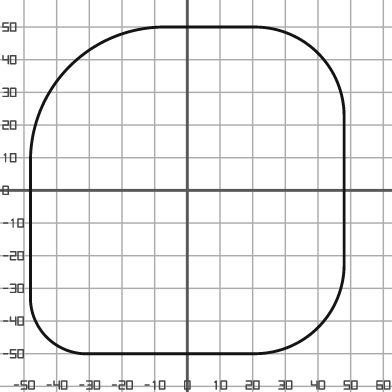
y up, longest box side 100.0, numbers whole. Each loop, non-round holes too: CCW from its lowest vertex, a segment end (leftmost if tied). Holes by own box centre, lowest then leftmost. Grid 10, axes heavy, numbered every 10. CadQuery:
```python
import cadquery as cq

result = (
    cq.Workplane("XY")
    .moveTo(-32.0, -50.0)
    .lineTo(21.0, -50.0)
    .threePointArc((40.0, -42.0), (48.0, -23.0))
    .lineTo(48.0, 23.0)
    .threePointArc((40.0, 42.0), (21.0, 50.0))
    .lineTo(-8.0, 50.0)
    .threePointArc((-36.0, 38.0), (-48.0, 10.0))
    .lineTo(-48.0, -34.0)
    .threePointArc((-43.0, -45.0), (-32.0, -50.0))
    .close()
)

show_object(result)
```